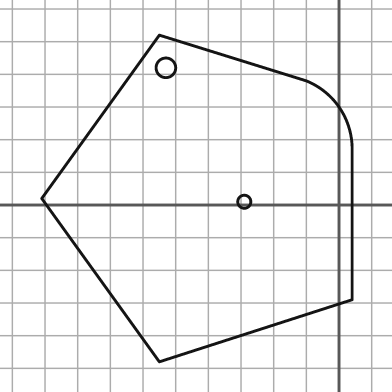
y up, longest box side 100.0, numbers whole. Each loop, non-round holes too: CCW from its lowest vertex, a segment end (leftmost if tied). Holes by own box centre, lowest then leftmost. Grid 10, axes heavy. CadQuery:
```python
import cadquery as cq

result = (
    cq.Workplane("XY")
    .moveTo(-55.0, -48.0)
    .lineTo(4.0, -29.0)
    .lineTo(4.0, 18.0)
    .threePointArc((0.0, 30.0), (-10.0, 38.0))
    .lineTo(-55.0, 52.0)
    .lineTo(-91.0, 2.0)
    .close()
    .moveTo(-29.0, 1.0)
    .circle(2.0)
    .moveTo(-53.0, 42.0)
    .circle(3.0)
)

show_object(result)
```